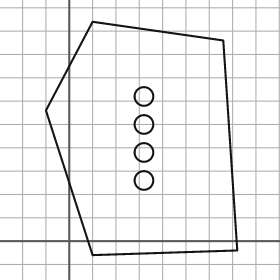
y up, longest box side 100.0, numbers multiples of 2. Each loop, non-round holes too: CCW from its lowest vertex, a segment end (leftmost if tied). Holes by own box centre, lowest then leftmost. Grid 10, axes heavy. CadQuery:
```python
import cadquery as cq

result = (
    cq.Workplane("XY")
    .moveTo(10.0, -6.0)
    .lineTo(72.0, -4.0)
    .lineTo(66.0, 86.0)
    .lineTo(10.0, 94.0)
    .lineTo(-10.0, 56.0)
    .close()
    .moveTo(32.0, 26.0)
    .circle(4.0)
    .moveTo(32.0, 38.0)
    .circle(4.0)
    .moveTo(32.0, 50.0)
    .circle(4.0)
    .moveTo(32.0, 62.0)
    .circle(4.0)
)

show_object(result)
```